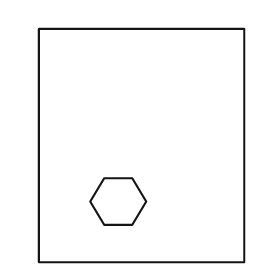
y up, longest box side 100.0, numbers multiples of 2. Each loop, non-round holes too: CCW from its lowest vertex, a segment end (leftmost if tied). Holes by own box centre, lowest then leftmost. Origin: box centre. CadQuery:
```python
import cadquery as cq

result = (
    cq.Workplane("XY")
    .moveTo(-44.0, -50.0)
    .lineTo(44.0, -50.0)
    .lineTo(44.0, 50.0)
    .lineTo(-44.0, 50.0)
    .close()
    .moveTo(-16.0, -34.0)
    .lineTo(-4.0, -34.0)
    .lineTo(2.0, -24.0)
    .lineTo(-4.0, -14.0)
    .lineTo(-16.0, -14.0)
    .lineTo(-22.0, -24.0)
    .close()
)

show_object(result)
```